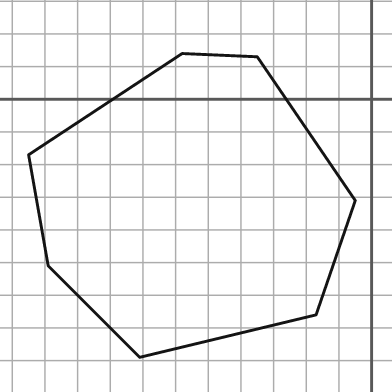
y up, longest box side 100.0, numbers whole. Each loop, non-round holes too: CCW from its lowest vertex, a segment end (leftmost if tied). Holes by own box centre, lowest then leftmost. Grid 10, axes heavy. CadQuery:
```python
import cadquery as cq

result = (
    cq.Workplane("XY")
    .moveTo(-71.0, -79.0)
    .lineTo(-17.0, -66.0)
    .lineTo(-5.0, -31.0)
    .lineTo(-35.0, 13.0)
    .lineTo(-58.0, 14.0)
    .lineTo(-105.0, -17.0)
    .lineTo(-99.0, -51.0)
    .close()
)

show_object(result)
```